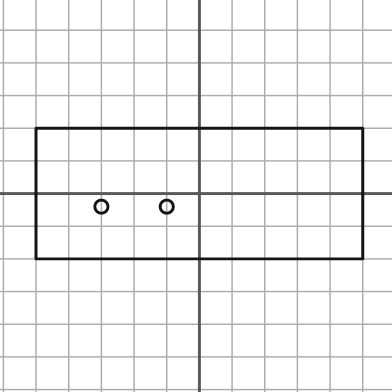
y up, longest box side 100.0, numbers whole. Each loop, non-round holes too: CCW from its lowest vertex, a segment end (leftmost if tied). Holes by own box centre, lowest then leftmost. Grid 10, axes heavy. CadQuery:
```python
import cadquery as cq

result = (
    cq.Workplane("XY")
    .moveTo(-50.0, -20.0)
    .lineTo(50.0, -20.0)
    .lineTo(50.0, 20.0)
    .lineTo(-50.0, 20.0)
    .close()
    .moveTo(-30.0, -4.0)
    .circle(2.0)
    .moveTo(-10.0, -4.0)
    .circle(2.0)
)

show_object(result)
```